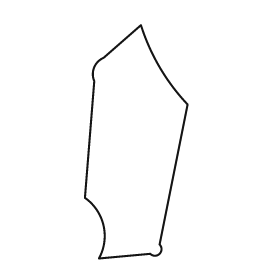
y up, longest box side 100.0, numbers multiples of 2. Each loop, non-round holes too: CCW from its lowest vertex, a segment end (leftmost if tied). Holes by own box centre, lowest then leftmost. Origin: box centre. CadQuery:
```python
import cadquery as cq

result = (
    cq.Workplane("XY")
    .moveTo(-16.0, -50.0)
    .lineTo(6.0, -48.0)
    .threePointArc((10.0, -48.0), (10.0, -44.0))
    .lineTo(22.0, 16.0)
    .threePointArc((10.0, 32.0), (2.0, 50.0))
    .lineTo(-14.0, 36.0)
    .threePointArc((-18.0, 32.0), (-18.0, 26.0))
    .lineTo(-22.0, -24.0)
    .threePointArc((-14.0, -36.0), (-16.0, -50.0))
    .close()
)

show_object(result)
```